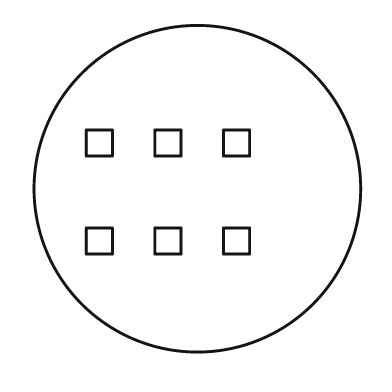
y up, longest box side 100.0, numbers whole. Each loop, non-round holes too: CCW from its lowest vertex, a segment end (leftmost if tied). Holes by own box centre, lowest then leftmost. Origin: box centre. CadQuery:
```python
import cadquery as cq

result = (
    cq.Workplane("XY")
    .moveTo(0.0, 0.0)
    .circle(50.0)
    .moveTo(-34.0, -20.0)
    .lineTo(-26.0, -20.0)
    .lineTo(-26.0, -12.0)
    .lineTo(-34.0, -12.0)
    .close()
    .moveTo(-13.0, -20.0)
    .lineTo(-5.0, -20.0)
    .lineTo(-5.0, -12.0)
    .lineTo(-13.0, -12.0)
    .close()
    .moveTo(8.0, -20.0)
    .lineTo(16.0, -20.0)
    .lineTo(16.0, -12.0)
    .lineTo(8.0, -12.0)
    .close()
    .moveTo(-34.0, 10.0)
    .lineTo(-26.0, 10.0)
    .lineTo(-26.0, 18.0)
    .lineTo(-34.0, 18.0)
    .close()
    .moveTo(-13.0, 10.0)
    .lineTo(-5.0, 10.0)
    .lineTo(-5.0, 18.0)
    .lineTo(-13.0, 18.0)
    .close()
    .moveTo(8.0, 10.0)
    .lineTo(16.0, 10.0)
    .lineTo(16.0, 18.0)
    .lineTo(8.0, 18.0)
    .close()
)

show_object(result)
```